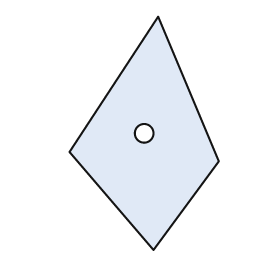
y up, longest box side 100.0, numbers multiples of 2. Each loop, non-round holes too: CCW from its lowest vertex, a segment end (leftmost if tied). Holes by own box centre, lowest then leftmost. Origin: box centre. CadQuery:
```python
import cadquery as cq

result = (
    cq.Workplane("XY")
    .moveTo(4.0, -50.0)
    .lineTo(32.0, -12.0)
    .lineTo(6.0, 50.0)
    .lineTo(-32.0, -8.0)
    .close()
    .moveTo(0.0, 0.0)
    .circle(4.0)
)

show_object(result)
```